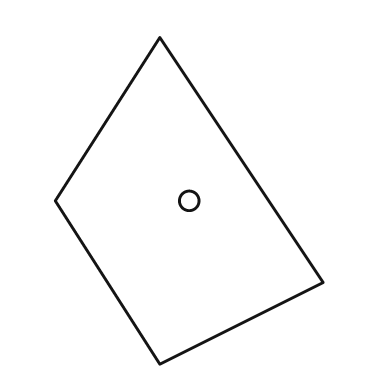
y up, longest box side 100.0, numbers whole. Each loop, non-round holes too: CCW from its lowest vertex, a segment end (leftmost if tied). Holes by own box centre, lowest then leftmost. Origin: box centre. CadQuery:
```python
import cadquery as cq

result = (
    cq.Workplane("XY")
    .moveTo(-9.0, -50.0)
    .lineTo(41.0, -25.0)
    .lineTo(-9.0, 50.0)
    .lineTo(-41.0, 0.0)
    .close()
    .moveTo(0.0, 0.0)
    .circle(3.0)
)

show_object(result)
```